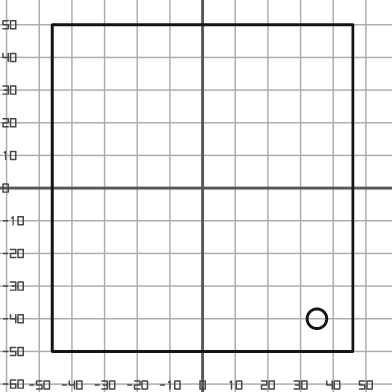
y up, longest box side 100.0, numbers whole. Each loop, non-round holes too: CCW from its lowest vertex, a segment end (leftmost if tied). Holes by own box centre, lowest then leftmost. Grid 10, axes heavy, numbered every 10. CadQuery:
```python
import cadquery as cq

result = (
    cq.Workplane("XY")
    .moveTo(-46.0, -50.0)
    .lineTo(46.0, -50.0)
    .lineTo(46.0, 50.0)
    .lineTo(-46.0, 50.0)
    .close()
    .moveTo(35.0, -40.0)
    .circle(3.0)
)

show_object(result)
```